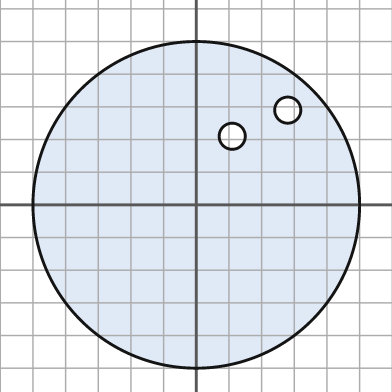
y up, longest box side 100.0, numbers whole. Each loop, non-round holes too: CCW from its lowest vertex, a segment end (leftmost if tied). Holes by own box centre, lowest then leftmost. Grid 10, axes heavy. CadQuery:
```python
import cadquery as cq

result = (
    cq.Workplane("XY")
    .moveTo(0.0, 0.0)
    .circle(50.0)
    .moveTo(11.0, 21.0)
    .circle(4.0)
    .moveTo(28.0, 29.0)
    .circle(4.0)
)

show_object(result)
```